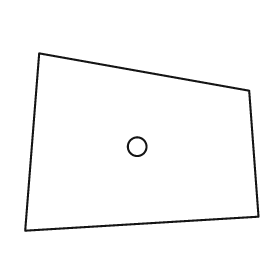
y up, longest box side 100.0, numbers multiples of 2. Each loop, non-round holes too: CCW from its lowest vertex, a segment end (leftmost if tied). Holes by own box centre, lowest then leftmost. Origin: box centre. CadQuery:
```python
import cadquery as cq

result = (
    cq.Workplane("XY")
    .moveTo(-50.0, -38.0)
    .lineTo(50.0, -32.0)
    .lineTo(46.0, 22.0)
    .lineTo(-44.0, 38.0)
    .close()
    .moveTo(-2.0, -2.0)
    .circle(4.0)
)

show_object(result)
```